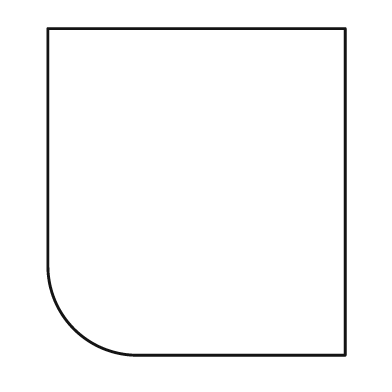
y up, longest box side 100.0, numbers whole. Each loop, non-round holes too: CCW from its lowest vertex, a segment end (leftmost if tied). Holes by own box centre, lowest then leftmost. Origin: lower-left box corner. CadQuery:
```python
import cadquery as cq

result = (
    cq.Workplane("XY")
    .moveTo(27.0, 0.0)
    .lineTo(91.0, 0.0)
    .lineTo(91.0, 100.0)
    .lineTo(0.0, 100.0)
    .lineTo(0.0, 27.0)
    .threePointArc((8.0, 8.0), (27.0, 0.0))
    .close()
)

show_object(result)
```